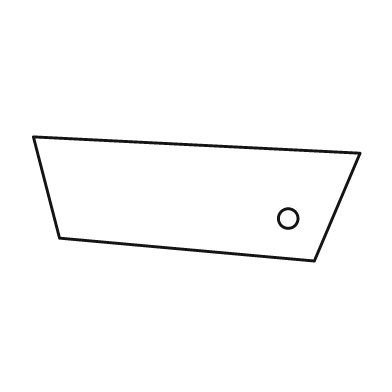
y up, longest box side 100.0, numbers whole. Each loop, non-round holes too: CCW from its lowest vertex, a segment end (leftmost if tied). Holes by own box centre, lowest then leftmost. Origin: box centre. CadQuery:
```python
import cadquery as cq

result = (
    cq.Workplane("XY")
    .moveTo(36.0, -19.0)
    .lineTo(50.0, 14.0)
    .lineTo(-50.0, 19.0)
    .lineTo(-42.0, -12.0)
    .close()
    .moveTo(28.0, -6.0)
    .circle(3.0)
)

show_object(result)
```